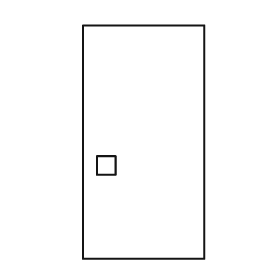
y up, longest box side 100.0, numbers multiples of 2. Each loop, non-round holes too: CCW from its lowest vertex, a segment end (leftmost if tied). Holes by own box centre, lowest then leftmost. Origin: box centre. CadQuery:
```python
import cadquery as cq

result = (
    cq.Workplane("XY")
    .moveTo(-26.0, -50.0)
    .lineTo(26.0, -50.0)
    .lineTo(26.0, 50.0)
    .lineTo(-26.0, 50.0)
    .close()
    .moveTo(-20.0, -14.0)
    .lineTo(-12.0, -14.0)
    .lineTo(-12.0, -6.0)
    .lineTo(-20.0, -6.0)
    .close()
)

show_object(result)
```